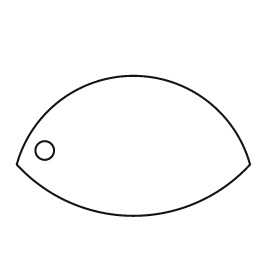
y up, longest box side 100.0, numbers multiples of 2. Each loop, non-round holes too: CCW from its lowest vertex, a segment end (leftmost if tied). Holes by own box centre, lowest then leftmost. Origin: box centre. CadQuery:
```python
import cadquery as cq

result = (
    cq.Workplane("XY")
    .moveTo(-50.0, -8.0)
    .threePointArc((0.0, -30.0), (50.0, -8.0))
    .threePointArc((0.0, 30.0), (-50.0, -8.0))
    .close()
    .moveTo(-38.0, -2.0)
    .circle(4.0)
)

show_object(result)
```